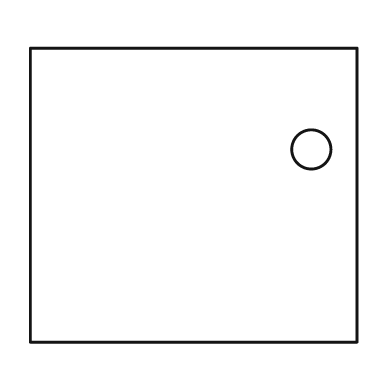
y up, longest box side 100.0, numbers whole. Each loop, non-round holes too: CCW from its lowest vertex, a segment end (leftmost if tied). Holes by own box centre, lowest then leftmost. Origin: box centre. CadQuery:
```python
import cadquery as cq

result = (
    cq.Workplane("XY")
    .moveTo(-50.0, -45.0)
    .lineTo(50.0, -45.0)
    .lineTo(50.0, 45.0)
    .lineTo(-50.0, 45.0)
    .close()
    .moveTo(36.0, 14.0)
    .circle(6.0)
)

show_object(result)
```